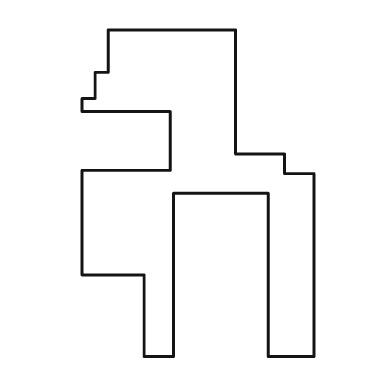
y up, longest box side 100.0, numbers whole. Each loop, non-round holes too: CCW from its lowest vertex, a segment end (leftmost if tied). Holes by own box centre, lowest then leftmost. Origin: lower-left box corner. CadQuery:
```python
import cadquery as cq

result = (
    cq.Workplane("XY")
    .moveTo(19.0, 0.0)
    .lineTo(28.0, 0.0)
    .lineTo(28.0, 50.0)
    .lineTo(57.0, 50.0)
    .lineTo(57.0, 0.0)
    .lineTo(71.0, 0.0)
    .lineTo(71.0, 56.0)
    .lineTo(62.0, 56.0)
    .lineTo(62.0, 62.0)
    .lineTo(47.0, 62.0)
    .lineTo(47.0, 100.0)
    .lineTo(8.0, 100.0)
    .lineTo(8.0, 87.0)
    .lineTo(4.0, 87.0)
    .lineTo(4.0, 79.0)
    .lineTo(0.0, 79.0)
    .lineTo(0.0, 75.0)
    .lineTo(27.0, 75.0)
    .lineTo(27.0, 57.0)
    .lineTo(0.0, 57.0)
    .lineTo(0.0, 25.0)
    .lineTo(19.0, 25.0)
    .close()
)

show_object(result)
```